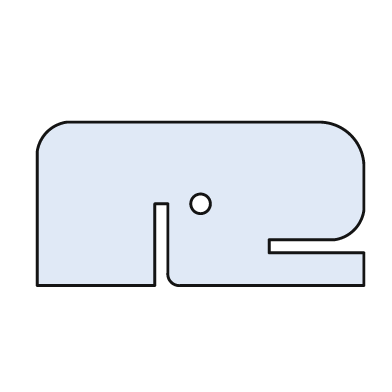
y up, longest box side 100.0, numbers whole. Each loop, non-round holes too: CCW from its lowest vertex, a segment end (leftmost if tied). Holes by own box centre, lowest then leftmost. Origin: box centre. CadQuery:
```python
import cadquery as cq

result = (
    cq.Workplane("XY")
    .moveTo(-50.0, -25.0)
    .lineTo(-14.0, -25.0)
    .lineTo(-14.0, 0.0)
    .lineTo(-10.0, 0.0)
    .lineTo(-10.0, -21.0)
    .threePointArc((-9.0, -24.0), (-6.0, -25.0))
    .lineTo(50.0, -25.0)
    .lineTo(50.0, -15.0)
    .lineTo(21.0, -15.0)
    .lineTo(21.0, -11.0)
    .lineTo(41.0, -11.0)
    .threePointArc((47.0, -8.0), (50.0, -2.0))
    .lineTo(50.0, 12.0)
    .threePointArc((46.0, 21.0), (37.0, 25.0))
    .lineTo(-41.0, 25.0)
    .threePointArc((-47.0, 22.0), (-50.0, 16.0))
    .close()
    .moveTo(0.0, 0.0)
    .circle(3.0)
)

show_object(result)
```